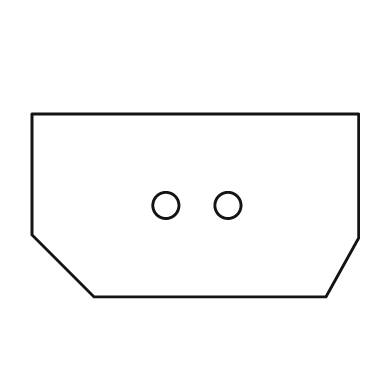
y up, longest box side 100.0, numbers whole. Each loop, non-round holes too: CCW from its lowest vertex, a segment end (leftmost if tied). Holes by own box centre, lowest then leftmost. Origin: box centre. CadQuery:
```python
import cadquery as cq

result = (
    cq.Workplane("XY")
    .moveTo(-31.0, -28.0)
    .lineTo(40.0, -28.0)
    .lineTo(50.0, -10.0)
    .lineTo(50.0, 28.0)
    .lineTo(-50.0, 28.0)
    .lineTo(-50.0, -9.0)
    .close()
    .moveTo(-9.0, 0.0)
    .circle(4.0)
    .moveTo(10.0, 0.0)
    .circle(4.0)
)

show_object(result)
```